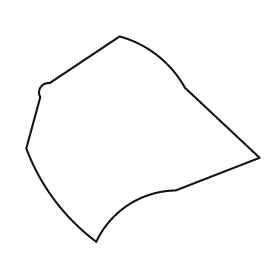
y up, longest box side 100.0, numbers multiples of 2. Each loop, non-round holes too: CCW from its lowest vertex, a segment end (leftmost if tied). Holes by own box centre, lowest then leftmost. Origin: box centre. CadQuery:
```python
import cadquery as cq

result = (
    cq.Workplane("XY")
    .moveTo(-20.0, -44.0)
    .threePointArc((-6.0, -28.0), (14.0, -22.0))
    .lineTo(50.0, -8.0)
    .lineTo(18.0, 22.0)
    .threePointArc((6.0, 36.0), (-10.0, 44.0))
    .lineTo(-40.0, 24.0)
    .threePointArc((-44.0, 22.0), (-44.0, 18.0))
    .lineTo(-50.0, -4.0)
    .threePointArc((-38.0, -26.0), (-20.0, -44.0))
    .close()
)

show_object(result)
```